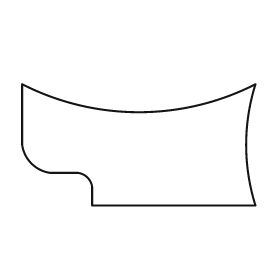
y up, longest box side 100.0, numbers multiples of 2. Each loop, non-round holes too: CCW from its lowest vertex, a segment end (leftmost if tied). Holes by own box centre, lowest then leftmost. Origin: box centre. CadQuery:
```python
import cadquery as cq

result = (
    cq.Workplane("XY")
    .moveTo(-20.0, -26.0)
    .lineTo(50.0, -26.0)
    .threePointArc((46.0, 0.0), (50.0, 26.0))
    .threePointArc((0.0, 14.0), (-50.0, 26.0))
    .lineTo(-50.0, 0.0)
    .threePointArc((-46.0, -8.0), (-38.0, -12.0))
    .lineTo(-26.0, -12.0)
    .threePointArc((-22.0, -14.0), (-20.0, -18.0))
    .close()
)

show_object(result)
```